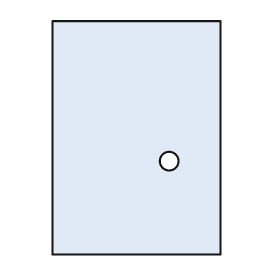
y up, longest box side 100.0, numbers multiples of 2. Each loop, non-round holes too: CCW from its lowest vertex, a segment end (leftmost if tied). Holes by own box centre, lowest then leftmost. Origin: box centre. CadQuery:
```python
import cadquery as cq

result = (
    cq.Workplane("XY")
    .moveTo(-36.0, -50.0)
    .lineTo(36.0, -50.0)
    .lineTo(36.0, 50.0)
    .lineTo(-36.0, 50.0)
    .close()
    .moveTo(14.0, -10.0)
    .circle(4.0)
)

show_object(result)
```